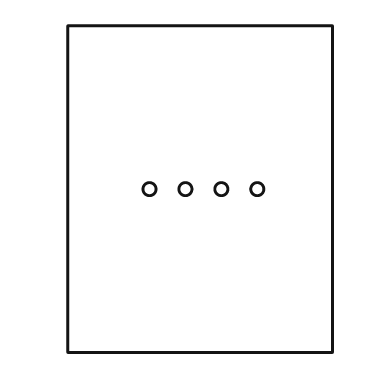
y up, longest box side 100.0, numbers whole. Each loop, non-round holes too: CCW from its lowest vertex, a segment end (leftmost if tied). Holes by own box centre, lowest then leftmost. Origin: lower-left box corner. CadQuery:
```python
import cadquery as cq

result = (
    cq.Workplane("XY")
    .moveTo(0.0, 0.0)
    .lineTo(81.0, 0.0)
    .lineTo(81.0, 100.0)
    .lineTo(0.0, 100.0)
    .close()
    .moveTo(25.0, 50.0)
    .circle(2.0)
    .moveTo(36.0, 50.0)
    .circle(2.0)
    .moveTo(47.0, 50.0)
    .circle(2.0)
    .moveTo(58.0, 50.0)
    .circle(2.0)
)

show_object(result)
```